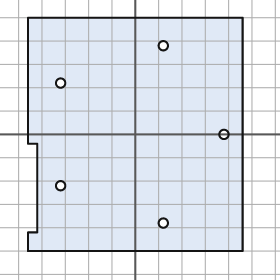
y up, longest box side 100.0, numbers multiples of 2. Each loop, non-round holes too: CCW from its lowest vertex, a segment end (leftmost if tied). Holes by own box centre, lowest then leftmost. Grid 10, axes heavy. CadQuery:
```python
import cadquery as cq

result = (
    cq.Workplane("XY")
    .moveTo(-46.0, -50.0)
    .lineTo(46.0, -50.0)
    .lineTo(46.0, 50.0)
    .lineTo(-46.0, 50.0)
    .lineTo(-46.0, -4.0)
    .lineTo(-42.0, -4.0)
    .lineTo(-42.0, -42.0)
    .lineTo(-46.0, -42.0)
    .close()
    .moveTo(12.0, -38.0)
    .circle(2.0)
    .moveTo(-32.0, -22.0)
    .circle(2.0)
    .moveTo(38.0, 0.0)
    .circle(2.0)
    .moveTo(-32.0, 22.0)
    .circle(2.0)
    .moveTo(12.0, 38.0)
    .circle(2.0)
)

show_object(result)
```